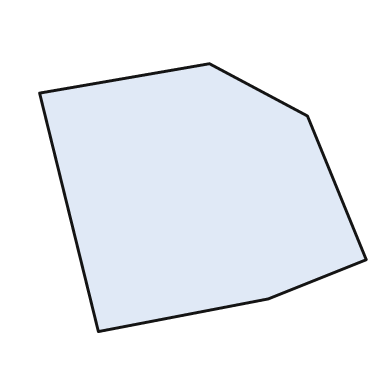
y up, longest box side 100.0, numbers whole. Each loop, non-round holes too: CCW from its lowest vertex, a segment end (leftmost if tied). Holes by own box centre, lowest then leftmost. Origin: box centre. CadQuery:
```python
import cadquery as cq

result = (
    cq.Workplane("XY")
    .moveTo(-32.0, -41.0)
    .lineTo(20.0, -31.0)
    .lineTo(50.0, -19.0)
    .lineTo(32.0, 25.0)
    .lineTo(2.0, 41.0)
    .lineTo(-50.0, 32.0)
    .close()
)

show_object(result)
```